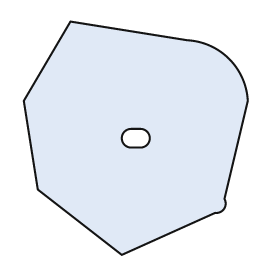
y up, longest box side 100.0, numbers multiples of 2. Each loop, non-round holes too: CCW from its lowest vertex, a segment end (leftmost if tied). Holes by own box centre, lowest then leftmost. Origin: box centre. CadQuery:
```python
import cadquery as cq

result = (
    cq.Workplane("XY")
    .moveTo(-6.0, -50.0)
    .lineTo(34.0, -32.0)
    .threePointArc((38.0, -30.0), (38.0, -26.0))
    .lineTo(48.0, 16.0)
    .threePointArc((40.0, 34.0), (22.0, 42.0))
    .lineTo(-28.0, 50.0)
    .lineTo(-48.0, 16.0)
    .lineTo(-42.0, -22.0)
    .close()
    .moveTo(-2.0, -4.0)
    .lineTo(2.0, -4.0)
    .threePointArc((6.0, 0.0), (2.0, 4.0))
    .lineTo(-2.0, 4.0)
    .threePointArc((-6.0, 0.0), (-2.0, -4.0))
    .close()
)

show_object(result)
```